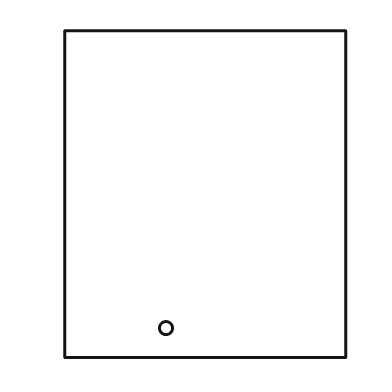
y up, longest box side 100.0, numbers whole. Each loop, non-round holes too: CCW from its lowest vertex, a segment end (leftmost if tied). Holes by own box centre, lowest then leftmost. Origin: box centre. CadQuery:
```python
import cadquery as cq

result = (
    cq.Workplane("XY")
    .moveTo(-43.0, -50.0)
    .lineTo(43.0, -50.0)
    .lineTo(43.0, 50.0)
    .lineTo(-43.0, 50.0)
    .close()
    .moveTo(-12.0, -41.0)
    .circle(2.0)
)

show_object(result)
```